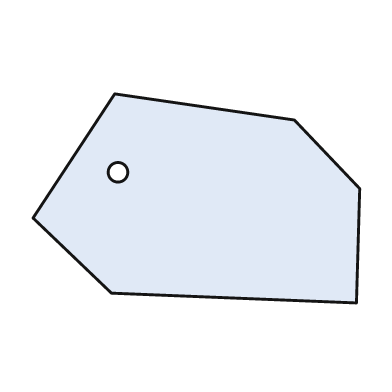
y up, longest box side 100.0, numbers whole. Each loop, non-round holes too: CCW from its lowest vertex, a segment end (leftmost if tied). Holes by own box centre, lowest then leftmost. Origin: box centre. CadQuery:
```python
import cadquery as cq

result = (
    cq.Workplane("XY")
    .moveTo(49.0, -32.0)
    .lineTo(50.0, 3.0)
    .lineTo(30.0, 24.0)
    .lineTo(-25.0, 32.0)
    .lineTo(-50.0, -6.0)
    .lineTo(-26.0, -29.0)
    .close()
    .moveTo(-24.0, 8.0)
    .circle(3.0)
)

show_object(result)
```